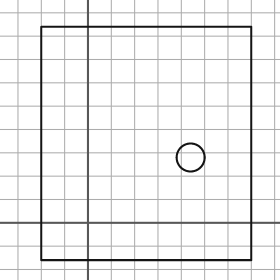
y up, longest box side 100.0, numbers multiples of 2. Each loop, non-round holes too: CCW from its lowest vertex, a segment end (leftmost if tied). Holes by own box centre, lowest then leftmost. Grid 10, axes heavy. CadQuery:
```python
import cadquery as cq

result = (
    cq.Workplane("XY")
    .moveTo(-20.0, -16.0)
    .lineTo(70.0, -16.0)
    .lineTo(70.0, 84.0)
    .lineTo(-20.0, 84.0)
    .close()
    .moveTo(44.0, 28.0)
    .circle(6.0)
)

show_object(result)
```